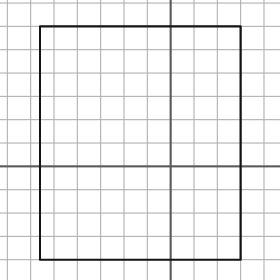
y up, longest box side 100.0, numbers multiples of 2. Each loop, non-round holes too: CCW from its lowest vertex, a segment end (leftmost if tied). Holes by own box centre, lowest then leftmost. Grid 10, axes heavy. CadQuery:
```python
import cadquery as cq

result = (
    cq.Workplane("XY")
    .moveTo(-56.0, -40.0)
    .lineTo(30.0, -40.0)
    .lineTo(30.0, 60.0)
    .lineTo(-56.0, 60.0)
    .close()
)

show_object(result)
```